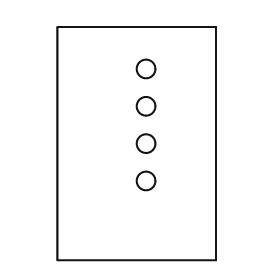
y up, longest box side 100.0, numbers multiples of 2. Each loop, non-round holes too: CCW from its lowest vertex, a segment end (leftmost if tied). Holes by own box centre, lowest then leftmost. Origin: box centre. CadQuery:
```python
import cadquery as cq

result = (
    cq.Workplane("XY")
    .moveTo(-34.0, -50.0)
    .lineTo(34.0, -50.0)
    .lineTo(34.0, 50.0)
    .lineTo(-34.0, 50.0)
    .close()
    .moveTo(4.0, -16.0)
    .circle(4.0)
    .moveTo(4.0, 0.0)
    .circle(4.0)
    .moveTo(4.0, 16.0)
    .circle(4.0)
    .moveTo(4.0, 32.0)
    .circle(4.0)
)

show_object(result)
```